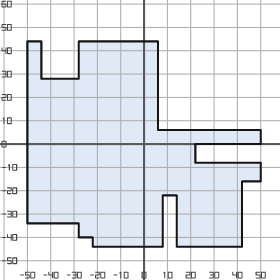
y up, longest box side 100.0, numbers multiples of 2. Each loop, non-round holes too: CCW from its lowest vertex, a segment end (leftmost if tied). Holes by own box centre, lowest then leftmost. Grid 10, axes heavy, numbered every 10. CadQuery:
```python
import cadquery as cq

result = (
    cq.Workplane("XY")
    .moveTo(-22.0, -44.0)
    .lineTo(8.0, -44.0)
    .lineTo(8.0, -22.0)
    .lineTo(14.0, -22.0)
    .lineTo(14.0, -44.0)
    .lineTo(42.0, -44.0)
    .lineTo(42.0, -16.0)
    .lineTo(50.0, -16.0)
    .lineTo(50.0, -8.0)
    .lineTo(22.0, -8.0)
    .lineTo(22.0, 0.0)
    .lineTo(50.0, 0.0)
    .lineTo(50.0, 6.0)
    .lineTo(6.0, 6.0)
    .lineTo(6.0, 44.0)
    .lineTo(-28.0, 44.0)
    .lineTo(-28.0, 28.0)
    .lineTo(-44.0, 28.0)
    .lineTo(-44.0, 44.0)
    .lineTo(-50.0, 44.0)
    .lineTo(-50.0, -34.0)
    .lineTo(-28.0, -34.0)
    .lineTo(-28.0, -40.0)
    .lineTo(-22.0, -40.0)
    .close()
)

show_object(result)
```